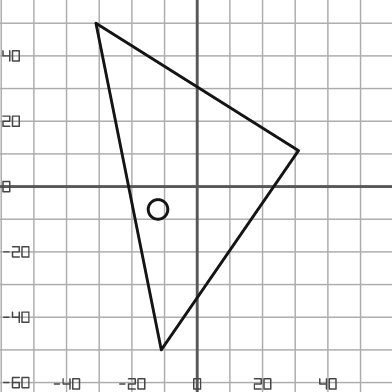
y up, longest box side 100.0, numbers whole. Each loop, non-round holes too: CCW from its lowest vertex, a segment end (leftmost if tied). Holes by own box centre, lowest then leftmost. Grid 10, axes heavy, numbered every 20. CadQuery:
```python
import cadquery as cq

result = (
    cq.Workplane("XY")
    .moveTo(-11.0, -50.0)
    .lineTo(31.0, 11.0)
    .lineTo(-31.0, 50.0)
    .close()
    .moveTo(-12.0, -7.0)
    .circle(3.0)
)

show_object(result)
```